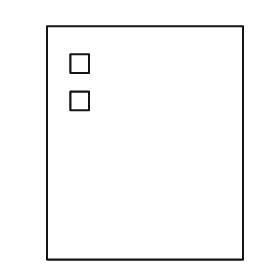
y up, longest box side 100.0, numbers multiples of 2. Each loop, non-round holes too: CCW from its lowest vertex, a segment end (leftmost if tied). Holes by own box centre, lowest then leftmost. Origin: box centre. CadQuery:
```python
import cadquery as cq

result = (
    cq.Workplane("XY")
    .moveTo(-42.0, -50.0)
    .lineTo(42.0, -50.0)
    .lineTo(42.0, 50.0)
    .lineTo(-42.0, 50.0)
    .close()
    .moveTo(-32.0, 14.0)
    .lineTo(-24.0, 14.0)
    .lineTo(-24.0, 22.0)
    .lineTo(-32.0, 22.0)
    .close()
    .moveTo(-32.0, 30.0)
    .lineTo(-24.0, 30.0)
    .lineTo(-24.0, 38.0)
    .lineTo(-32.0, 38.0)
    .close()
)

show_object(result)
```